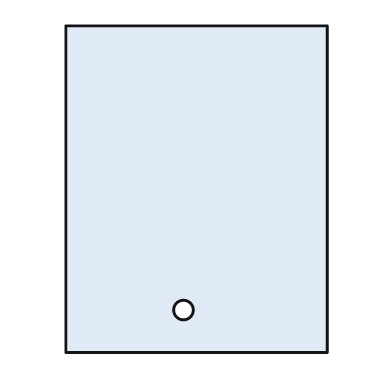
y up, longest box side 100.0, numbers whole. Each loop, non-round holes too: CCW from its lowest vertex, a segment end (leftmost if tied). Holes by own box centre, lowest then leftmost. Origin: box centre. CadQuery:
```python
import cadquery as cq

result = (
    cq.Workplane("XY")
    .moveTo(-40.0, -50.0)
    .lineTo(40.0, -50.0)
    .lineTo(40.0, 50.0)
    .lineTo(-40.0, 50.0)
    .close()
    .moveTo(-4.0, -37.0)
    .circle(3.0)
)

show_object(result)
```